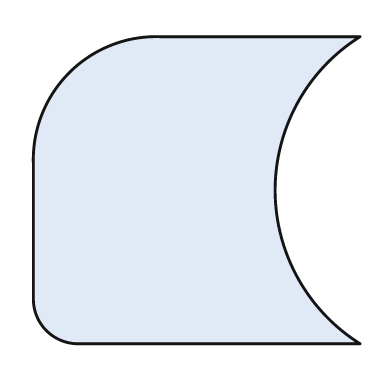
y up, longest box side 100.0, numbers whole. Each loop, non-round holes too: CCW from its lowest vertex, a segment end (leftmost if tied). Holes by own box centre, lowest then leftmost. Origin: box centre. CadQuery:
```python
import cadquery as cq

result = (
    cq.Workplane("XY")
    .moveTo(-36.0, -47.0)
    .lineTo(50.0, -47.0)
    .threePointArc((24.0, 0.0), (50.0, 47.0))
    .lineTo(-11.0, 47.0)
    .threePointArc((-39.0, 36.0), (-50.0, 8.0))
    .lineTo(-50.0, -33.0)
    .threePointArc((-46.0, -43.0), (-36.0, -47.0))
    .close()
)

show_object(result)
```